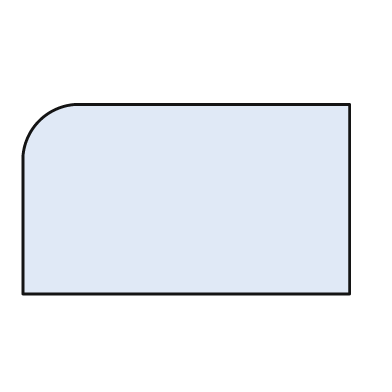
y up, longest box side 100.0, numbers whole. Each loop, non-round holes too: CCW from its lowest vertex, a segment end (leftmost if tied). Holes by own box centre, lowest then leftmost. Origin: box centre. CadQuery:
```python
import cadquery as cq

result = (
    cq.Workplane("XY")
    .moveTo(-50.0, -29.0)
    .lineTo(50.0, -29.0)
    .lineTo(50.0, 29.0)
    .lineTo(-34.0, 29.0)
    .threePointArc((-45.0, 24.0), (-50.0, 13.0))
    .close()
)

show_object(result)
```